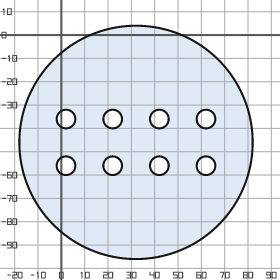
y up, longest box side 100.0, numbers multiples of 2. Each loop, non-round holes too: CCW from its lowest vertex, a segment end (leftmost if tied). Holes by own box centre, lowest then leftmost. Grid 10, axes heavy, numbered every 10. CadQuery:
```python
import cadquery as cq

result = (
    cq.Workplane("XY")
    .moveTo(32.0, -46.0)
    .circle(50.0)
    .moveTo(2.0, -56.0)
    .circle(4.0)
    .moveTo(22.0, -56.0)
    .circle(4.0)
    .moveTo(42.0, -56.0)
    .circle(4.0)
    .moveTo(62.0, -56.0)
    .circle(4.0)
    .moveTo(2.0, -36.0)
    .circle(4.0)
    .moveTo(22.0, -36.0)
    .circle(4.0)
    .moveTo(42.0, -36.0)
    .circle(4.0)
    .moveTo(62.0, -36.0)
    .circle(4.0)
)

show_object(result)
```